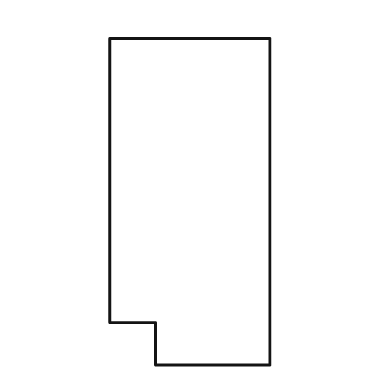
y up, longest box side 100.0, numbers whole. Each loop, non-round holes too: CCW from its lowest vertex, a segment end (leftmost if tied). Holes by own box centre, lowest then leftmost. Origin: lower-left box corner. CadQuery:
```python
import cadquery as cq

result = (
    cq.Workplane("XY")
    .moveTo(14.0, 0.0)
    .lineTo(49.0, 0.0)
    .lineTo(49.0, 100.0)
    .lineTo(0.0, 100.0)
    .lineTo(0.0, 13.0)
    .lineTo(14.0, 13.0)
    .close()
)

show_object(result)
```